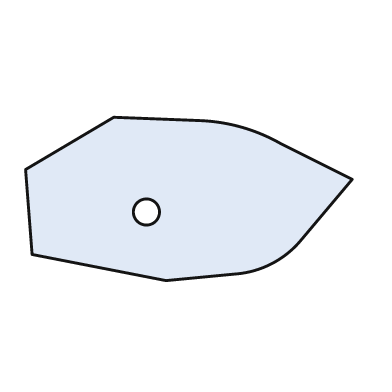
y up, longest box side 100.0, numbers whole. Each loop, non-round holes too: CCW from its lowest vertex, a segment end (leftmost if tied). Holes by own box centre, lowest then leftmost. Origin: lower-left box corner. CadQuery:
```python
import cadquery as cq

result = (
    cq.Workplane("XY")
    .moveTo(43.0, 0.0)
    .lineTo(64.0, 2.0)
    .threePointArc((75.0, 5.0), (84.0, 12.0))
    .lineTo(100.0, 31.0)
    .lineTo(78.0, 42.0)
    .threePointArc((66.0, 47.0), (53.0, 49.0))
    .lineTo(27.0, 50.0)
    .lineTo(0.0, 34.0)
    .lineTo(2.0, 8.0)
    .close()
    .moveTo(37.0, 21.0)
    .circle(4.0)
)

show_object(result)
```